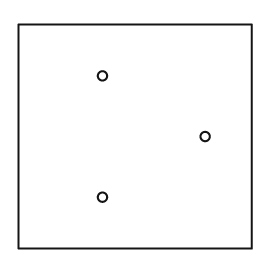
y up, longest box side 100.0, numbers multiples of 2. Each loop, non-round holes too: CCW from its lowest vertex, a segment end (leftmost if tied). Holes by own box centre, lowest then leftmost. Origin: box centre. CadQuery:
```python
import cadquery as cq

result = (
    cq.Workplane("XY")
    .moveTo(-50.0, -48.0)
    .lineTo(50.0, -48.0)
    .lineTo(50.0, 48.0)
    .lineTo(-50.0, 48.0)
    .close()
    .moveTo(-14.0, -26.0)
    .circle(2.0)
    .moveTo(30.0, 0.0)
    .circle(2.0)
    .moveTo(-14.0, 26.0)
    .circle(2.0)
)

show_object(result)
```